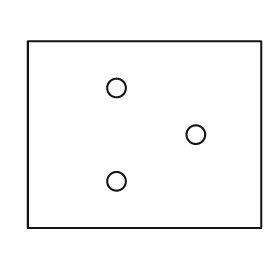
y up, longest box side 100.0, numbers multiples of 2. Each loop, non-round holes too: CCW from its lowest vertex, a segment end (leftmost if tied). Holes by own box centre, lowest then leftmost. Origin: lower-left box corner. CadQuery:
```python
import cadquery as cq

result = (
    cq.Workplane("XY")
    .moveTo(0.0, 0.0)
    .lineTo(100.0, 0.0)
    .lineTo(100.0, 80.0)
    .lineTo(0.0, 80.0)
    .close()
    .moveTo(38.0, 20.0)
    .circle(4.0)
    .moveTo(72.0, 40.0)
    .circle(4.0)
    .moveTo(38.0, 60.0)
    .circle(4.0)
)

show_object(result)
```